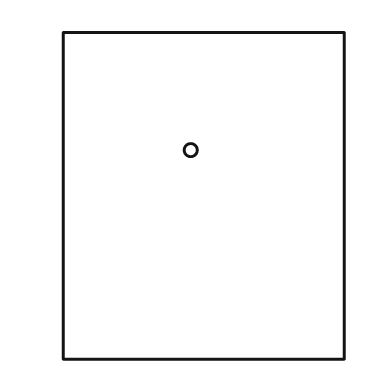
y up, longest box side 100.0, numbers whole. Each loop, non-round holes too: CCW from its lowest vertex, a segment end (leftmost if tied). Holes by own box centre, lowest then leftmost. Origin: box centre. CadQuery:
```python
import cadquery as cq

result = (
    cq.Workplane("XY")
    .moveTo(-43.0, -50.0)
    .lineTo(43.0, -50.0)
    .lineTo(43.0, 50.0)
    .lineTo(-43.0, 50.0)
    .close()
    .moveTo(-4.0, 14.0)
    .circle(2.0)
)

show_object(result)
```